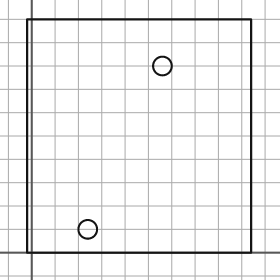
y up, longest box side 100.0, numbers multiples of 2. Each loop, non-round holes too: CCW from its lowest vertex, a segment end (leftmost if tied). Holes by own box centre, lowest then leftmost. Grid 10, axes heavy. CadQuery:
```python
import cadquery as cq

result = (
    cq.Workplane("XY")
    .moveTo(-2.0, 0.0)
    .lineTo(94.0, 0.0)
    .lineTo(94.0, 100.0)
    .lineTo(-2.0, 100.0)
    .close()
    .moveTo(24.0, 10.0)
    .circle(4.0)
    .moveTo(56.0, 80.0)
    .circle(4.0)
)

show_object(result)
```